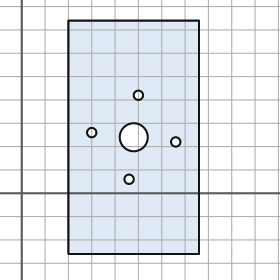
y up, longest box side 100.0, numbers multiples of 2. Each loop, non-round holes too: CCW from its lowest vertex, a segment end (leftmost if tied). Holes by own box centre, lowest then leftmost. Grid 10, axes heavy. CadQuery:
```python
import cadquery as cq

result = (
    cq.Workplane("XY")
    .moveTo(20.0, -26.0)
    .lineTo(76.0, -26.0)
    .lineTo(76.0, 74.0)
    .lineTo(20.0, 74.0)
    .close()
    .moveTo(46.0, 6.0)
    .circle(2.0)
    .moveTo(66.0, 22.0)
    .circle(2.0)
    .moveTo(48.0, 24.0)
    .circle(6.0)
    .moveTo(30.0, 26.0)
    .circle(2.0)
    .moveTo(50.0, 42.0)
    .circle(2.0)
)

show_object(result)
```